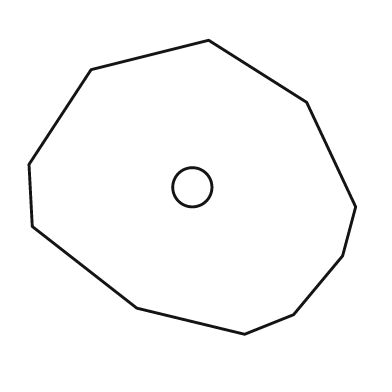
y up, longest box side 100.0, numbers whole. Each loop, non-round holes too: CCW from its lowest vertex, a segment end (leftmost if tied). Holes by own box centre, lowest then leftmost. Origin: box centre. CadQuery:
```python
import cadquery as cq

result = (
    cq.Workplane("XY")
    .moveTo(16.0, -45.0)
    .lineTo(31.0, -39.0)
    .lineTo(46.0, -21.0)
    .lineTo(50.0, -6.0)
    .lineTo(35.0, 26.0)
    .lineTo(5.0, 45.0)
    .lineTo(-31.0, 36.0)
    .lineTo(-50.0, 7.0)
    .lineTo(-49.0, -12.0)
    .lineTo(-17.0, -37.0)
    .close()
    .moveTo(0.0, 0.0)
    .circle(6.0)
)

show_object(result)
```